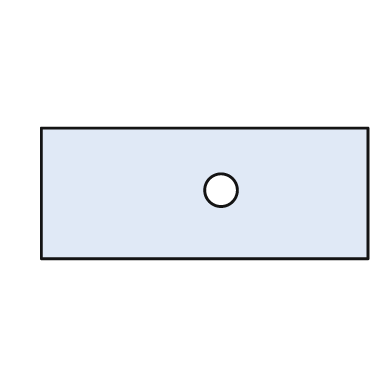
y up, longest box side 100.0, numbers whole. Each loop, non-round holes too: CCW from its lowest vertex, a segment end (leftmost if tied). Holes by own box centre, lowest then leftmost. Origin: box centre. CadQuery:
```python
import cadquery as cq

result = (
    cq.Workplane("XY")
    .moveTo(-50.0, -20.0)
    .lineTo(50.0, -20.0)
    .lineTo(50.0, 20.0)
    .lineTo(-50.0, 20.0)
    .close()
    .moveTo(5.0, 1.0)
    .circle(5.0)
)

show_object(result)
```